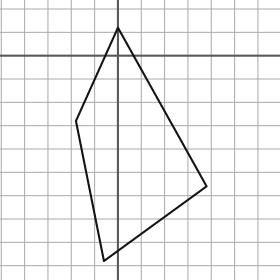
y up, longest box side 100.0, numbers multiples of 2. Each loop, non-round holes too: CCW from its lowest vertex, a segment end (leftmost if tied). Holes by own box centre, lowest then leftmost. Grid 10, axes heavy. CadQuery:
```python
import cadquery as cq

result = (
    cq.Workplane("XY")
    .moveTo(-6.0, -88.0)
    .lineTo(38.0, -56.0)
    .lineTo(0.0, 12.0)
    .lineTo(-18.0, -28.0)
    .close()
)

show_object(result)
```